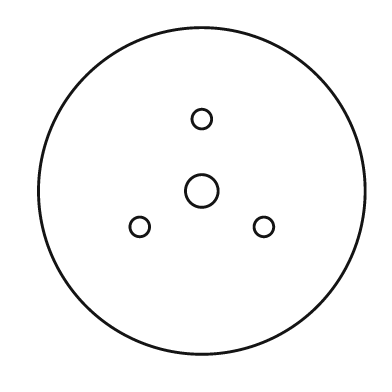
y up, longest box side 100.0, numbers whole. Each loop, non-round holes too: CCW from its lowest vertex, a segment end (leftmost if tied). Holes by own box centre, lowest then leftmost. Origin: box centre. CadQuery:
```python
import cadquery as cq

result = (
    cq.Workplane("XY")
    .moveTo(0.0, 0.0)
    .circle(50.0)
    .moveTo(-19.0, -11.0)
    .circle(3.0)
    .moveTo(19.0, -11.0)
    .circle(3.0)
    .moveTo(0.0, 0.0)
    .circle(5.0)
    .moveTo(0.0, 22.0)
    .circle(3.0)
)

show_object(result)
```